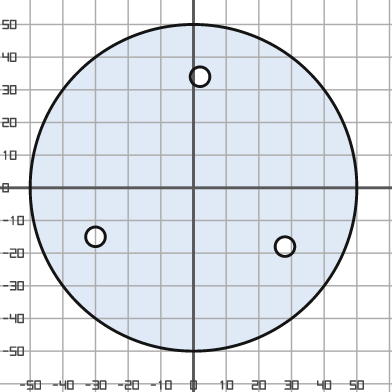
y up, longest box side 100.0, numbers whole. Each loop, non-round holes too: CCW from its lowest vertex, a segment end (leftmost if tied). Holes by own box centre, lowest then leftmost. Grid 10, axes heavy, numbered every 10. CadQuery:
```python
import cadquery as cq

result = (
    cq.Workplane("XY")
    .moveTo(0.0, 0.0)
    .circle(50.0)
    .moveTo(28.0, -18.0)
    .circle(3.0)
    .moveTo(-30.0, -15.0)
    .circle(3.0)
    .moveTo(2.0, 34.0)
    .circle(3.0)
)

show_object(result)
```